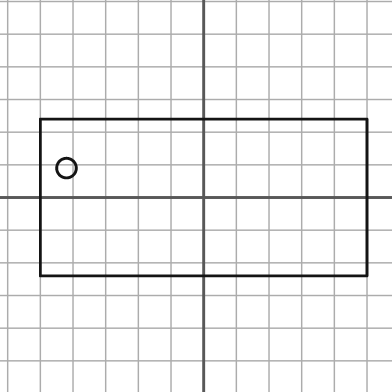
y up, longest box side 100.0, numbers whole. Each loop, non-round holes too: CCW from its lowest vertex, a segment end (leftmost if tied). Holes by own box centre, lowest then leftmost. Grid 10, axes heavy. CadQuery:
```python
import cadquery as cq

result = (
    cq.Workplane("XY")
    .moveTo(-50.0, -24.0)
    .lineTo(50.0, -24.0)
    .lineTo(50.0, 24.0)
    .lineTo(-50.0, 24.0)
    .close()
    .moveTo(-42.0, 9.0)
    .circle(3.0)
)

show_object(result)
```